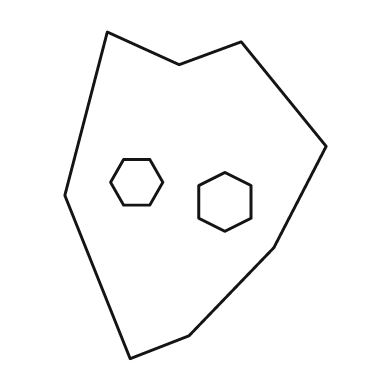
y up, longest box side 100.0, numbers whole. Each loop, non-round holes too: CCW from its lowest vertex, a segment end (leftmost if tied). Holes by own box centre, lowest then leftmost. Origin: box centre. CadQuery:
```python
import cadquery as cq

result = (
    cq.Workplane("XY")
    .moveTo(-20.0, -50.0)
    .lineTo(-2.0, -43.0)
    .lineTo(24.0, -16.0)
    .lineTo(40.0, 15.0)
    .lineTo(14.0, 47.0)
    .lineTo(-5.0, 40.0)
    .lineTo(-27.0, 50.0)
    .lineTo(-40.0, 0.0)
    .close()
    .moveTo(9.0, -11.0)
    .lineTo(17.0, -7.0)
    .lineTo(17.0, 3.0)
    .lineTo(9.0, 7.0)
    .lineTo(1.0, 3.0)
    .lineTo(1.0, -7.0)
    .close()
    .moveTo(-22.0, -3.0)
    .lineTo(-14.0, -3.0)
    .lineTo(-10.0, 4.0)
    .lineTo(-14.0, 11.0)
    .lineTo(-22.0, 11.0)
    .lineTo(-26.0, 4.0)
    .close()
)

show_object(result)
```